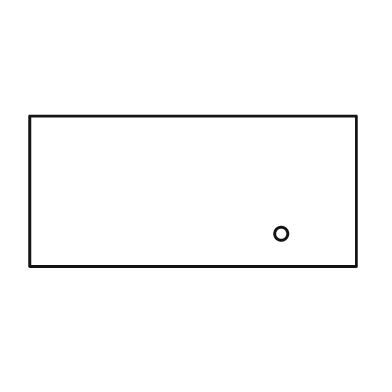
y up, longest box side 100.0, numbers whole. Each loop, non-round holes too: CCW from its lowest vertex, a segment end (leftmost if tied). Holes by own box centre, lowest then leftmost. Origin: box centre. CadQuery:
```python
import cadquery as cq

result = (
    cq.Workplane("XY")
    .moveTo(-50.0, -23.0)
    .lineTo(50.0, -23.0)
    .lineTo(50.0, 23.0)
    .lineTo(-50.0, 23.0)
    .close()
    .moveTo(27.0, -13.0)
    .circle(2.0)
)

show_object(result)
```